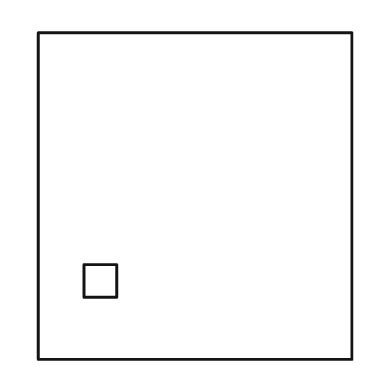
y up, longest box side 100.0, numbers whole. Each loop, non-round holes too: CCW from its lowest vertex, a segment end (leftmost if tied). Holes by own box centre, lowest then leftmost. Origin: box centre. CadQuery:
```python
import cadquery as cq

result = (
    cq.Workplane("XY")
    .moveTo(-48.0, -50.0)
    .lineTo(48.0, -50.0)
    .lineTo(48.0, 50.0)
    .lineTo(-48.0, 50.0)
    .close()
    .moveTo(-34.0, -31.0)
    .lineTo(-24.0, -31.0)
    .lineTo(-24.0, -21.0)
    .lineTo(-34.0, -21.0)
    .close()
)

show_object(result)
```